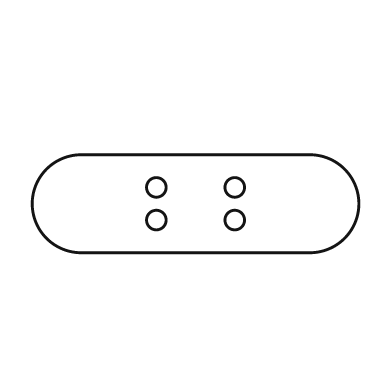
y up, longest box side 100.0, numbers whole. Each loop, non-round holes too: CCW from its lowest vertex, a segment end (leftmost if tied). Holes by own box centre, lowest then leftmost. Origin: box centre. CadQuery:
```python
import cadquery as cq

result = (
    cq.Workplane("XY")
    .moveTo(-35.0, -15.0)
    .lineTo(35.0, -15.0)
    .threePointArc((50.0, 0.0), (35.0, 15.0))
    .lineTo(-35.0, 15.0)
    .threePointArc((-50.0, 0.0), (-35.0, -15.0))
    .close()
    .moveTo(-12.0, -5.0)
    .circle(3.0)
    .moveTo(12.0, -5.0)
    .circle(3.0)
    .moveTo(-12.0, 5.0)
    .circle(3.0)
    .moveTo(12.0, 5.0)
    .circle(3.0)
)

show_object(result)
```